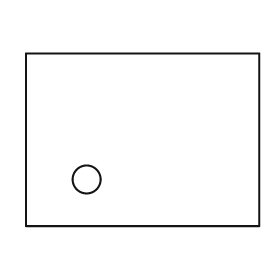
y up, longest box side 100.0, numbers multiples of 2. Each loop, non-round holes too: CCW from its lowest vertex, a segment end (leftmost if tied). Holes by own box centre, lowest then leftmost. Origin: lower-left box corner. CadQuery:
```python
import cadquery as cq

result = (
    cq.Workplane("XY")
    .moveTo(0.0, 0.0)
    .lineTo(100.0, 0.0)
    .lineTo(100.0, 74.0)
    .lineTo(0.0, 74.0)
    .close()
    .moveTo(26.0, 20.0)
    .circle(6.0)
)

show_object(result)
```